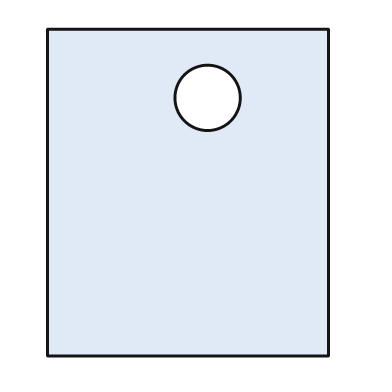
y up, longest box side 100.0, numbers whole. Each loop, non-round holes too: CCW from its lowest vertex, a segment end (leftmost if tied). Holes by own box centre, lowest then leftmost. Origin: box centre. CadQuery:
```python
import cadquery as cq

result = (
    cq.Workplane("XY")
    .moveTo(-43.0, -50.0)
    .lineTo(43.0, -50.0)
    .lineTo(43.0, 50.0)
    .lineTo(-43.0, 50.0)
    .close()
    .moveTo(6.0, 29.0)
    .circle(10.0)
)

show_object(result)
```